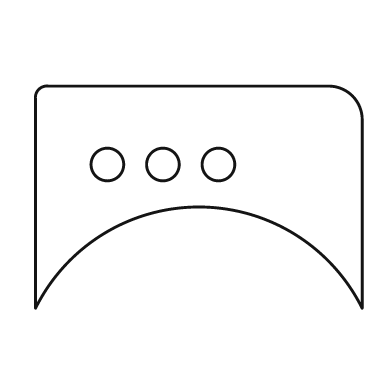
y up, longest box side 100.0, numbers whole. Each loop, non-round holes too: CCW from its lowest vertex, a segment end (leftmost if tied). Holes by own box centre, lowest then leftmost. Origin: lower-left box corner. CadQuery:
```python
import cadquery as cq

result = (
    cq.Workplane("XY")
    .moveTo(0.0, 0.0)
    .threePointArc((50.0, 31.0), (100.0, 0.0))
    .lineTo(100.0, 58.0)
    .threePointArc((97.0, 65.0), (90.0, 68.0))
    .lineTo(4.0, 68.0)
    .threePointArc((1.0, 67.0), (0.0, 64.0))
    .close()
    .moveTo(22.0, 44.0)
    .circle(5.0)
    .moveTo(39.0, 44.0)
    .circle(5.0)
    .moveTo(56.0, 44.0)
    .circle(5.0)
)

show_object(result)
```